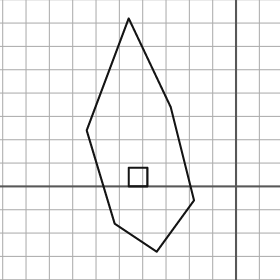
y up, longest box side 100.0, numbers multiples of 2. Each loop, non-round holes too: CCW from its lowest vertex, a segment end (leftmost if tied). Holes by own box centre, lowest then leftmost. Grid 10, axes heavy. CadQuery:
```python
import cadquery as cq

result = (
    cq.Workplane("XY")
    .moveTo(-34.0, -28.0)
    .lineTo(-18.0, -6.0)
    .lineTo(-28.0, 34.0)
    .lineTo(-46.0, 72.0)
    .lineTo(-64.0, 24.0)
    .lineTo(-52.0, -16.0)
    .close()
    .moveTo(-46.0, 0.0)
    .lineTo(-38.0, 0.0)
    .lineTo(-38.0, 8.0)
    .lineTo(-46.0, 8.0)
    .close()
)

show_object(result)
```